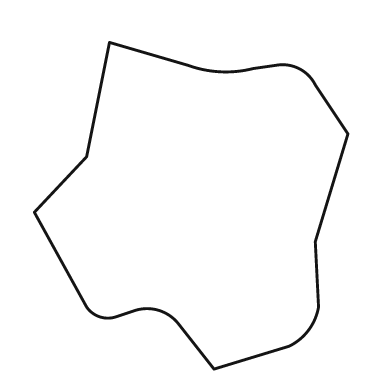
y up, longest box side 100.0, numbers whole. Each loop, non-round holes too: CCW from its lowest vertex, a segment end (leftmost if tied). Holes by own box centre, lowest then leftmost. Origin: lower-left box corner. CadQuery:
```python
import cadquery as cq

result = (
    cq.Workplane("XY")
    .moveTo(55.0, 0.0)
    .lineTo(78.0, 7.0)
    .threePointArc((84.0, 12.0), (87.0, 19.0))
    .lineTo(86.0, 39.0)
    .lineTo(96.0, 72.0)
    .lineTo(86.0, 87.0)
    .threePointArc((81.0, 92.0), (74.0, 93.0))
    .lineTo(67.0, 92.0)
    .threePointArc((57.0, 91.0), (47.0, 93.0))
    .lineTo(23.0, 100.0)
    .lineTo(16.0, 65.0)
    .lineTo(0.0, 48.0)
    .lineTo(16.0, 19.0)
    .threePointArc((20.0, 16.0), (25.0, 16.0))
    .lineTo(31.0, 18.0)
    .threePointArc((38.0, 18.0), (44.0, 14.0))
    .close()
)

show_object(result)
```